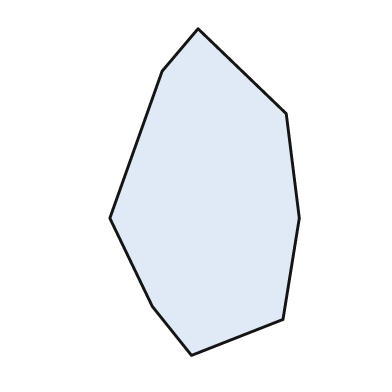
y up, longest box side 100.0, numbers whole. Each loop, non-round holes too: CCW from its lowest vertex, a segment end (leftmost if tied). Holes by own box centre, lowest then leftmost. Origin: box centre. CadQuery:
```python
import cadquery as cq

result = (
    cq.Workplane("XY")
    .moveTo(-4.0, -50.0)
    .lineTo(24.0, -39.0)
    .lineTo(29.0, -8.0)
    .lineTo(25.0, 24.0)
    .lineTo(-2.0, 50.0)
    .lineTo(-13.0, 37.0)
    .lineTo(-29.0, -8.0)
    .lineTo(-16.0, -35.0)
    .close()
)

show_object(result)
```